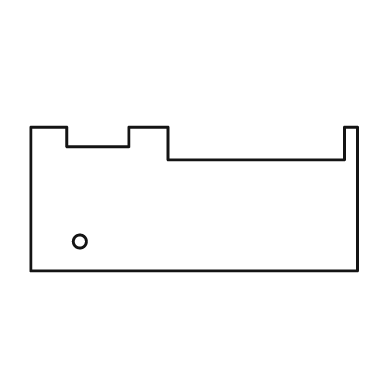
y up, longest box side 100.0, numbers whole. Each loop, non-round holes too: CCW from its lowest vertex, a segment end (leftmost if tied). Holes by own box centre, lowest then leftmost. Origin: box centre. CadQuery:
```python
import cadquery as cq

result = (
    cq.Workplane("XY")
    .moveTo(-50.0, -22.0)
    .lineTo(50.0, -22.0)
    .lineTo(50.0, 22.0)
    .lineTo(46.0, 22.0)
    .lineTo(46.0, 12.0)
    .lineTo(-8.0, 12.0)
    .lineTo(-8.0, 22.0)
    .lineTo(-20.0, 22.0)
    .lineTo(-20.0, 16.0)
    .lineTo(-39.0, 16.0)
    .lineTo(-39.0, 22.0)
    .lineTo(-50.0, 22.0)
    .close()
    .moveTo(-35.0, -13.0)
    .circle(2.0)
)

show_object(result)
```